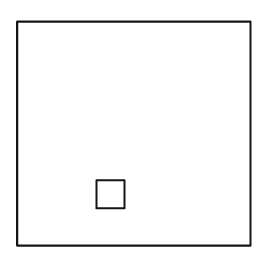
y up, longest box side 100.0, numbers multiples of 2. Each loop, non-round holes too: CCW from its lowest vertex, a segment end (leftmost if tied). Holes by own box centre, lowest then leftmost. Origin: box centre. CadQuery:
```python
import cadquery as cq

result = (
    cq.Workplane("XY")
    .moveTo(-50.0, -48.0)
    .lineTo(50.0, -48.0)
    .lineTo(50.0, 48.0)
    .lineTo(-50.0, 48.0)
    .close()
    .moveTo(-16.0, -32.0)
    .lineTo(-4.0, -32.0)
    .lineTo(-4.0, -20.0)
    .lineTo(-16.0, -20.0)
    .close()
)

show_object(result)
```